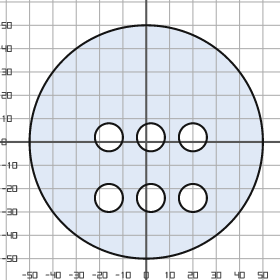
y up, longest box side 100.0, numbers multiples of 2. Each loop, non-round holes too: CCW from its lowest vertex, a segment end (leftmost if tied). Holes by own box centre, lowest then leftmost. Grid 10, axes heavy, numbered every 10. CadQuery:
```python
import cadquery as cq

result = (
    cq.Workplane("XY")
    .moveTo(0.0, 0.0)
    .circle(50.0)
    .moveTo(-16.0, -24.0)
    .circle(6.0)
    .moveTo(2.0, -24.0)
    .circle(6.0)
    .moveTo(20.0, -24.0)
    .circle(6.0)
    .moveTo(-16.0, 2.0)
    .circle(6.0)
    .moveTo(2.0, 2.0)
    .circle(6.0)
    .moveTo(20.0, 2.0)
    .circle(6.0)
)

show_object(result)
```